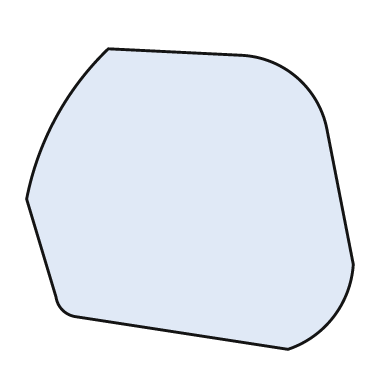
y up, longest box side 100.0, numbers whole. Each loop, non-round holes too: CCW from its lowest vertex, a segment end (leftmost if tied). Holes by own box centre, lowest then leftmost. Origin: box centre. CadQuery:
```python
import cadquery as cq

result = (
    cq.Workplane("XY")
    .moveTo(30.0, -46.0)
    .threePointArc((44.0, -36.0), (50.0, -20.0))
    .lineTo(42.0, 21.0)
    .threePointArc((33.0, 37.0), (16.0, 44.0))
    .lineTo(-25.0, 46.0)
    .threePointArc((-41.0, 25.0), (-50.0, 0.0))
    .lineTo(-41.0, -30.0)
    .threePointArc((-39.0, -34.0), (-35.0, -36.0))
    .close()
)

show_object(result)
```